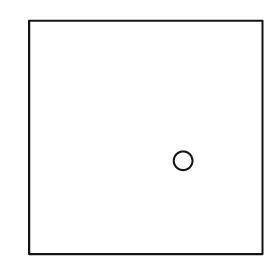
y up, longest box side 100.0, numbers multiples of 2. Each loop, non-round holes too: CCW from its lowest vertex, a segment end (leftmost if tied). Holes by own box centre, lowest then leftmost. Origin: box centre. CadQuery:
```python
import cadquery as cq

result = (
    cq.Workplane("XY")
    .moveTo(-50.0, -50.0)
    .lineTo(50.0, -50.0)
    .lineTo(50.0, 50.0)
    .lineTo(-50.0, 50.0)
    .close()
    .moveTo(16.0, -10.0)
    .circle(4.0)
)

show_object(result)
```